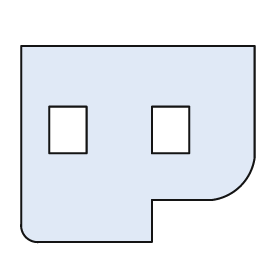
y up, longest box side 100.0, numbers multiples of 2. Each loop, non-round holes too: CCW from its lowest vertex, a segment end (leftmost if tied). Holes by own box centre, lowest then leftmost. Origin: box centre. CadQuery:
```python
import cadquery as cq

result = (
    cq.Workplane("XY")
    .moveTo(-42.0, -42.0)
    .lineTo(6.0, -42.0)
    .lineTo(6.0, -24.0)
    .lineTo(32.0, -24.0)
    .threePointArc((44.0, -18.0), (50.0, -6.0))
    .lineTo(50.0, 42.0)
    .lineTo(-50.0, 42.0)
    .lineTo(-50.0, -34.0)
    .threePointArc((-48.0, -40.0), (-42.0, -42.0))
    .close()
    .moveTo(-38.0, -4.0)
    .lineTo(-22.0, -4.0)
    .lineTo(-22.0, 16.0)
    .lineTo(-38.0, 16.0)
    .close()
    .moveTo(6.0, -4.0)
    .lineTo(22.0, -4.0)
    .lineTo(22.0, 16.0)
    .lineTo(6.0, 16.0)
    .close()
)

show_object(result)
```